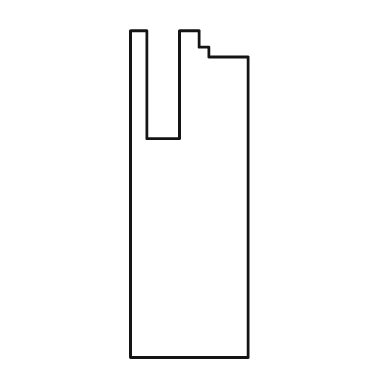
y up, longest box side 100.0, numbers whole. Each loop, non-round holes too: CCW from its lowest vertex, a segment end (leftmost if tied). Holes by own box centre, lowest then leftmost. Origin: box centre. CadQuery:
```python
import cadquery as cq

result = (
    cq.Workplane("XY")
    .moveTo(-18.0, -50.0)
    .lineTo(18.0, -50.0)
    .lineTo(18.0, 42.0)
    .lineTo(6.0, 42.0)
    .lineTo(6.0, 45.0)
    .lineTo(3.0, 45.0)
    .lineTo(3.0, 50.0)
    .lineTo(-3.0, 50.0)
    .lineTo(-3.0, 17.0)
    .lineTo(-13.0, 17.0)
    .lineTo(-13.0, 50.0)
    .lineTo(-18.0, 50.0)
    .close()
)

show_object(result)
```